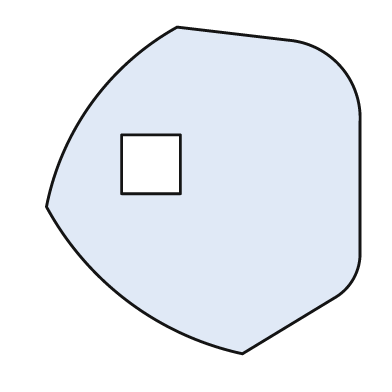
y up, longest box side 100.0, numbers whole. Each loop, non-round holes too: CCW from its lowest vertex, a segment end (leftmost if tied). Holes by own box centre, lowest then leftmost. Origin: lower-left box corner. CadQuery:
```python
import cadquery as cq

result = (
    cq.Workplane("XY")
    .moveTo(60.0, 0.0)
    .lineTo(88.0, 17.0)
    .threePointArc((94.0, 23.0), (96.0, 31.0))
    .lineTo(96.0, 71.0)
    .threePointArc((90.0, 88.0), (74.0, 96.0))
    .lineTo(40.0, 100.0)
    .threePointArc((14.0, 77.0), (0.0, 45.0))
    .threePointArc((25.0, 16.0), (60.0, 0.0))
    .close()
    .moveTo(23.0, 49.0)
    .lineTo(41.0, 49.0)
    .lineTo(41.0, 67.0)
    .lineTo(23.0, 67.0)
    .close()
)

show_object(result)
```